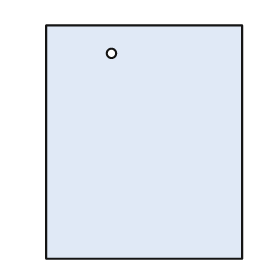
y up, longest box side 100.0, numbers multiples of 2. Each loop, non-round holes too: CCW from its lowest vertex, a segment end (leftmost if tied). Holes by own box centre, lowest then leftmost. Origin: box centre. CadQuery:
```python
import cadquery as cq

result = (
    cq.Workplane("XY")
    .moveTo(-42.0, -50.0)
    .lineTo(42.0, -50.0)
    .lineTo(42.0, 50.0)
    .lineTo(-42.0, 50.0)
    .close()
    .moveTo(-14.0, 38.0)
    .circle(2.0)
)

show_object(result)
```